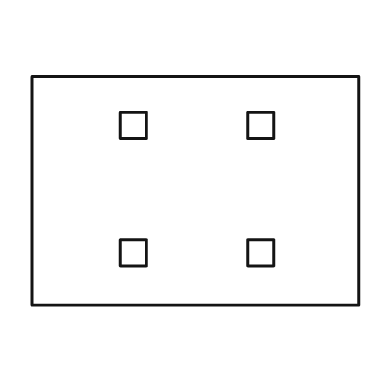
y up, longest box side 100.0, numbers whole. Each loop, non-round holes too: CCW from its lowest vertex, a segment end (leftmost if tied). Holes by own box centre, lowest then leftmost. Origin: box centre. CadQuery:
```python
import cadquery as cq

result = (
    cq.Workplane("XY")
    .moveTo(-50.0, -35.0)
    .lineTo(50.0, -35.0)
    .lineTo(50.0, 35.0)
    .lineTo(-50.0, 35.0)
    .close()
    .moveTo(-23.0, -23.0)
    .lineTo(-15.0, -23.0)
    .lineTo(-15.0, -15.0)
    .lineTo(-23.0, -15.0)
    .close()
    .moveTo(16.0, -23.0)
    .lineTo(24.0, -23.0)
    .lineTo(24.0, -15.0)
    .lineTo(16.0, -15.0)
    .close()
    .moveTo(-23.0, 16.0)
    .lineTo(-15.0, 16.0)
    .lineTo(-15.0, 24.0)
    .lineTo(-23.0, 24.0)
    .close()
    .moveTo(16.0, 16.0)
    .lineTo(24.0, 16.0)
    .lineTo(24.0, 24.0)
    .lineTo(16.0, 24.0)
    .close()
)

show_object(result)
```